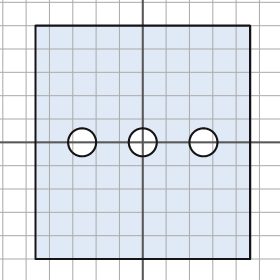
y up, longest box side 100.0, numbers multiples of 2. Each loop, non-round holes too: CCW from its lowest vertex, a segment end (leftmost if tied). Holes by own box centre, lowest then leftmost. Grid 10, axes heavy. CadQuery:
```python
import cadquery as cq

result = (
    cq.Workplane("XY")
    .moveTo(-46.0, -50.0)
    .lineTo(46.0, -50.0)
    .lineTo(46.0, 50.0)
    .lineTo(-46.0, 50.0)
    .close()
    .moveTo(-26.0, 0.0)
    .circle(6.0)
    .moveTo(0.0, 0.0)
    .circle(6.0)
    .moveTo(26.0, 0.0)
    .circle(6.0)
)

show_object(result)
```